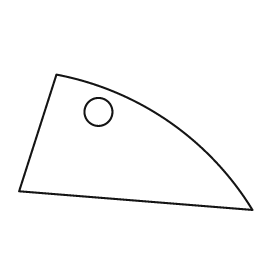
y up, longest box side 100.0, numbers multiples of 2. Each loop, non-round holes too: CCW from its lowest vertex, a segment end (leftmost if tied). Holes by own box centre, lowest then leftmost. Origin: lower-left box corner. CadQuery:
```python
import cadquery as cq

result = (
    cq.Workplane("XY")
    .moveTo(100.0, 0.0)
    .threePointArc((64.0, 38.0), (16.0, 58.0))
    .lineTo(0.0, 8.0)
    .close()
    .moveTo(34.0, 42.0)
    .circle(6.0)
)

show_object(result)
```